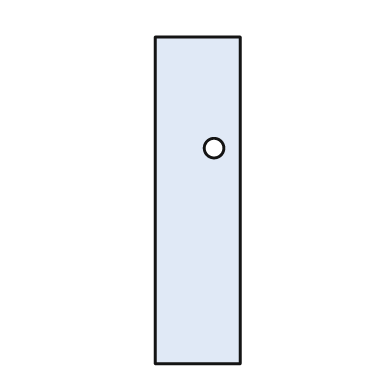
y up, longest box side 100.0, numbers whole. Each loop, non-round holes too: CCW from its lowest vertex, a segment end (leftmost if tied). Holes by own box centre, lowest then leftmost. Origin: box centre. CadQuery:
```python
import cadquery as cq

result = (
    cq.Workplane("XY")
    .moveTo(-13.0, -50.0)
    .lineTo(13.0, -50.0)
    .lineTo(13.0, 50.0)
    .lineTo(-13.0, 50.0)
    .close()
    .moveTo(5.0, 16.0)
    .circle(3.0)
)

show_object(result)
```